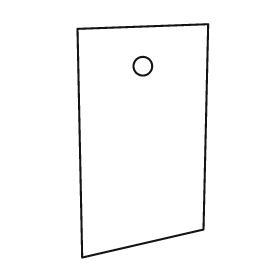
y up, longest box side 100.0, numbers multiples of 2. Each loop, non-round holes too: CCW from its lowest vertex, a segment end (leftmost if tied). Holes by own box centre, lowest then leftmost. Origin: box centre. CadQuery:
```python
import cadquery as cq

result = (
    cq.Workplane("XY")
    .moveTo(-26.0, -50.0)
    .lineTo(26.0, -38.0)
    .lineTo(28.0, 50.0)
    .lineTo(-28.0, 48.0)
    .close()
    .moveTo(0.0, 32.0)
    .circle(4.0)
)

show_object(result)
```